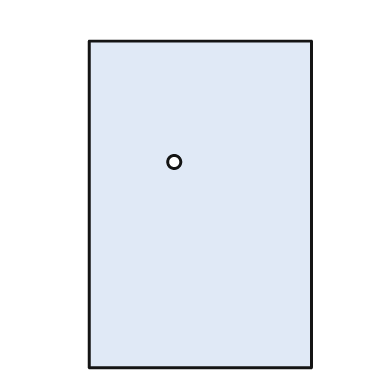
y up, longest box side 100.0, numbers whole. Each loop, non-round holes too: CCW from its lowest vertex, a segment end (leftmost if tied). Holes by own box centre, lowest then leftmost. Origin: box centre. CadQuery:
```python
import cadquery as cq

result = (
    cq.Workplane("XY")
    .moveTo(-34.0, -50.0)
    .lineTo(34.0, -50.0)
    .lineTo(34.0, 50.0)
    .lineTo(-34.0, 50.0)
    .close()
    .moveTo(-8.0, 13.0)
    .circle(2.0)
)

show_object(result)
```